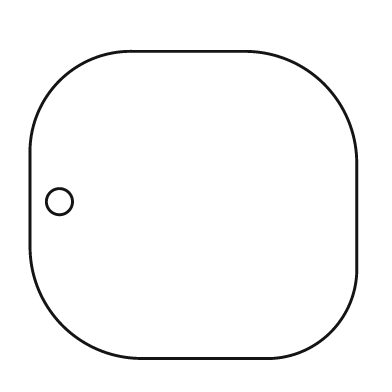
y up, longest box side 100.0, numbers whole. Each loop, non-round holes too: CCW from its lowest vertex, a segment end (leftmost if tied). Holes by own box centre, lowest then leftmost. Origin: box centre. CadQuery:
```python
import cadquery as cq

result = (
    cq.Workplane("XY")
    .moveTo(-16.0, -47.0)
    .lineTo(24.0, -47.0)
    .threePointArc((42.0, -39.0), (50.0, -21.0))
    .lineTo(50.0, 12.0)
    .threePointArc((40.0, 37.0), (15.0, 47.0))
    .lineTo(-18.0, 47.0)
    .threePointArc((-41.0, 38.0), (-50.0, 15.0))
    .lineTo(-50.0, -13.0)
    .threePointArc((-40.0, -37.0), (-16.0, -47.0))
    .close()
    .moveTo(-41.0, 1.0)
    .circle(4.0)
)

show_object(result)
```